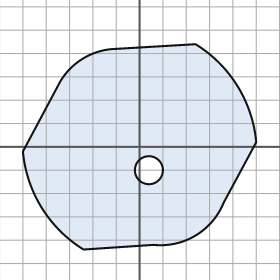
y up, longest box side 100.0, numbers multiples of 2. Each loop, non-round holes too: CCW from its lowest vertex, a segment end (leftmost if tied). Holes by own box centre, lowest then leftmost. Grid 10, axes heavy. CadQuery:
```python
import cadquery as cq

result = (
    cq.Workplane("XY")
    .moveTo(-24.0, -44.0)
    .lineTo(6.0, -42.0)
    .threePointArc((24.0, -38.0), (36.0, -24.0))
    .lineTo(50.0, 2.0)
    .threePointArc((42.0, 26.0), (24.0, 44.0))
    .lineTo(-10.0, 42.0)
    .threePointArc((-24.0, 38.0), (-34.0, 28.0))
    .lineTo(-50.0, -2.0)
    .threePointArc((-42.0, -26.0), (-24.0, -44.0))
    .close()
    .moveTo(4.0, -10.0)
    .circle(6.0)
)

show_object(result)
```